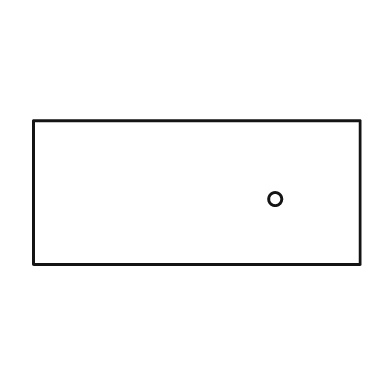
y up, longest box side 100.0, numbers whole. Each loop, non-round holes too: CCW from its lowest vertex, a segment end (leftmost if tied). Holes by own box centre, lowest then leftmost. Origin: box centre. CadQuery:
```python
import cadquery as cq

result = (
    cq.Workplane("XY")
    .moveTo(-50.0, -22.0)
    .lineTo(50.0, -22.0)
    .lineTo(50.0, 22.0)
    .lineTo(-50.0, 22.0)
    .close()
    .moveTo(24.0, -2.0)
    .circle(2.0)
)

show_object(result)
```